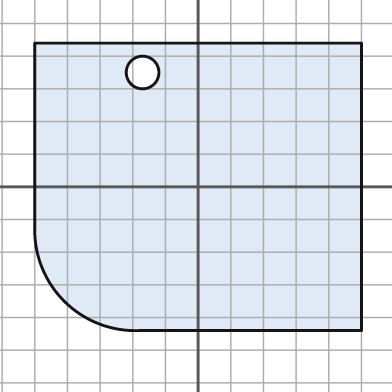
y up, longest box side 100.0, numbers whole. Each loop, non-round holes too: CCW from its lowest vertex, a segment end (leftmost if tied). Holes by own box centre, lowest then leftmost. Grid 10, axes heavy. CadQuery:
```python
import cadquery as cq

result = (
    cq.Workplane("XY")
    .moveTo(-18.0, -44.0)
    .lineTo(50.0, -44.0)
    .lineTo(50.0, 44.0)
    .lineTo(-50.0, 44.0)
    .lineTo(-50.0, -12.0)
    .threePointArc((-41.0, -35.0), (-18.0, -44.0))
    .close()
    .moveTo(-17.0, 35.0)
    .circle(5.0)
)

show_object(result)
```